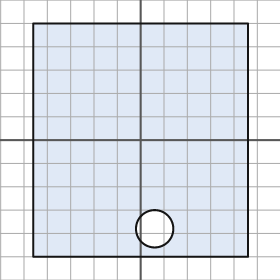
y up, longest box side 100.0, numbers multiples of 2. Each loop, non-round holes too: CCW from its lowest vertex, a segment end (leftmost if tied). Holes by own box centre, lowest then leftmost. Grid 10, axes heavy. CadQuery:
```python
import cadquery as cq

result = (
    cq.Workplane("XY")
    .moveTo(-46.0, -50.0)
    .lineTo(46.0, -50.0)
    .lineTo(46.0, 50.0)
    .lineTo(-46.0, 50.0)
    .close()
    .moveTo(6.0, -38.0)
    .circle(8.0)
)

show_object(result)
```